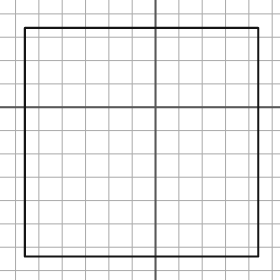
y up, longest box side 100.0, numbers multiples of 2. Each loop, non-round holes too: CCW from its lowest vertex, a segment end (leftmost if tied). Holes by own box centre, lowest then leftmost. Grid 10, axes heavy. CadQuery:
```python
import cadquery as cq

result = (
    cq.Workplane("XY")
    .moveTo(-56.0, -64.0)
    .lineTo(44.0, -64.0)
    .lineTo(44.0, 34.0)
    .lineTo(-56.0, 34.0)
    .close()
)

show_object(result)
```